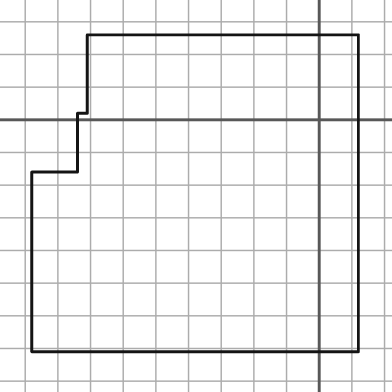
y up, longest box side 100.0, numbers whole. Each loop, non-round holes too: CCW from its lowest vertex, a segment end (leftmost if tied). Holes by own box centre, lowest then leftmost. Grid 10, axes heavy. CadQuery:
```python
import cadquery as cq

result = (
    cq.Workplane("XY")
    .moveTo(-88.0, -71.0)
    .lineTo(12.0, -71.0)
    .lineTo(12.0, 26.0)
    .lineTo(-71.0, 26.0)
    .lineTo(-71.0, 2.0)
    .lineTo(-74.0, 2.0)
    .lineTo(-74.0, -16.0)
    .lineTo(-88.0, -16.0)
    .close()
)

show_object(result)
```